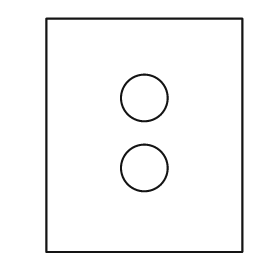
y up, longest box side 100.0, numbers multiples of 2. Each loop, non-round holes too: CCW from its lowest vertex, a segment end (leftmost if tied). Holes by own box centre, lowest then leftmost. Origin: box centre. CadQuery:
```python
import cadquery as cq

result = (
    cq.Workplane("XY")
    .moveTo(-42.0, -50.0)
    .lineTo(42.0, -50.0)
    .lineTo(42.0, 50.0)
    .lineTo(-42.0, 50.0)
    .close()
    .moveTo(0.0, -14.0)
    .circle(10.0)
    .moveTo(0.0, 16.0)
    .circle(10.0)
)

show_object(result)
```